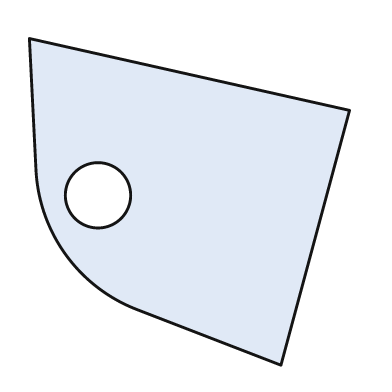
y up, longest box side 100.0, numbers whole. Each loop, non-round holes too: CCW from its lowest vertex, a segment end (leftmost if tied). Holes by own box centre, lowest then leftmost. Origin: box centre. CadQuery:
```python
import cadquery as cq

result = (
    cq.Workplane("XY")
    .moveTo(28.0, -50.0)
    .lineTo(49.0, 28.0)
    .lineTo(-49.0, 50.0)
    .lineTo(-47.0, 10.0)
    .threePointArc((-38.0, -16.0), (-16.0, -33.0))
    .close()
    .moveTo(-28.0, 2.0)
    .circle(10.0)
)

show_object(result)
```